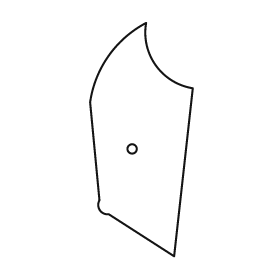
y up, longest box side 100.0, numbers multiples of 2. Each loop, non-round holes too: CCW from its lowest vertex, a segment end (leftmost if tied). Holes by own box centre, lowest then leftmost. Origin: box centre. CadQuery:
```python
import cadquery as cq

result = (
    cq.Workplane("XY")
    .moveTo(14.0, -50.0)
    .lineTo(22.0, 22.0)
    .threePointArc((6.0, 32.0), (2.0, 50.0))
    .threePointArc((-14.0, 36.0), (-22.0, 16.0))
    .lineTo(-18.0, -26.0)
    .threePointArc((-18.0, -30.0), (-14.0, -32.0))
    .close()
    .moveTo(-4.0, -4.0)
    .circle(2.0)
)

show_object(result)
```